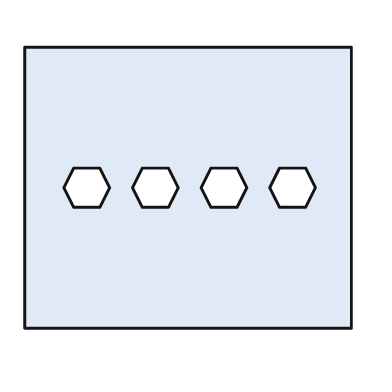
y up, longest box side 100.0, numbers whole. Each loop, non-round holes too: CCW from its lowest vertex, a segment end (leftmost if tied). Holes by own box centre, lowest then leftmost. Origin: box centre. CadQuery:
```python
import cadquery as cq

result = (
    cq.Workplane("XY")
    .moveTo(-50.0, -43.0)
    .lineTo(50.0, -43.0)
    .lineTo(50.0, 43.0)
    .lineTo(-50.0, 43.0)
    .close()
    .moveTo(-35.0, -6.0)
    .lineTo(-27.0, -6.0)
    .lineTo(-24.0, 0.0)
    .lineTo(-27.0, 6.0)
    .lineTo(-35.0, 6.0)
    .lineTo(-38.0, 0.0)
    .close()
    .moveTo(-14.0, -6.0)
    .lineTo(-6.0, -6.0)
    .lineTo(-3.0, 0.0)
    .lineTo(-6.0, 6.0)
    .lineTo(-14.0, 6.0)
    .lineTo(-17.0, 0.0)
    .close()
    .moveTo(7.0, -6.0)
    .lineTo(15.0, -6.0)
    .lineTo(18.0, 0.0)
    .lineTo(15.0, 6.0)
    .lineTo(7.0, 6.0)
    .lineTo(4.0, 0.0)
    .close()
    .moveTo(28.0, -6.0)
    .lineTo(36.0, -6.0)
    .lineTo(39.0, 0.0)
    .lineTo(36.0, 6.0)
    .lineTo(28.0, 6.0)
    .lineTo(25.0, 0.0)
    .close()
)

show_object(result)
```